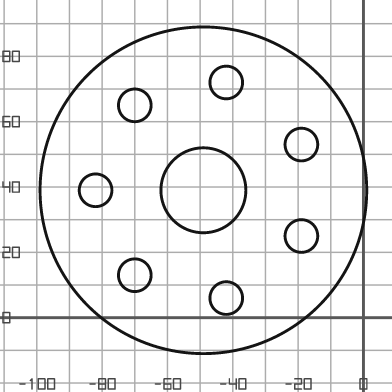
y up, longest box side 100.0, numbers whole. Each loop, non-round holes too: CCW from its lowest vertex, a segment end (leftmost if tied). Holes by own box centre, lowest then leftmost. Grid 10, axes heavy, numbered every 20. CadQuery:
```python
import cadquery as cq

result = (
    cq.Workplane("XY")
    .moveTo(-49.0, 39.0)
    .circle(50.0)
    .moveTo(-42.0, 6.0)
    .circle(5.0)
    .moveTo(-70.0, 13.0)
    .circle(5.0)
    .moveTo(-19.0, 25.0)
    .circle(5.0)
    .moveTo(-82.0, 39.0)
    .circle(5.0)
    .moveTo(-49.0, 39.0)
    .circle(13.0)
    .moveTo(-19.0, 53.0)
    .circle(5.0)
    .moveTo(-70.0, 65.0)
    .circle(5.0)
    .moveTo(-42.0, 72.0)
    .circle(5.0)
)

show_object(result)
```